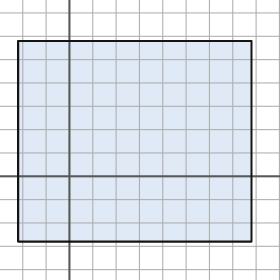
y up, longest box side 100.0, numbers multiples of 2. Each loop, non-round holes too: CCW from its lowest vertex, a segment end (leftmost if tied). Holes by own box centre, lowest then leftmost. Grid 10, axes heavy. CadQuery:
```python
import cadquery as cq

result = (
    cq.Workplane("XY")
    .moveTo(-22.0, -28.0)
    .lineTo(78.0, -28.0)
    .lineTo(78.0, 58.0)
    .lineTo(-22.0, 58.0)
    .close()
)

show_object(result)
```